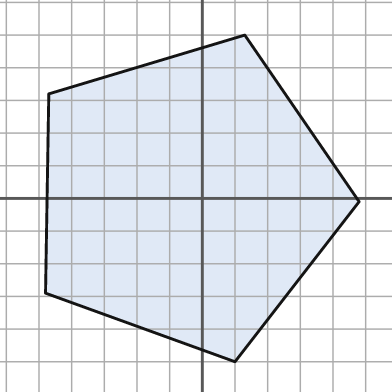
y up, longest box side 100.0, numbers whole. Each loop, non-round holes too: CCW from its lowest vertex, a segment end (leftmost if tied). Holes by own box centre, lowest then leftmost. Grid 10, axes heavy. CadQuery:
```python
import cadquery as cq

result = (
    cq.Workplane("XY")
    .moveTo(10.0, -50.0)
    .lineTo(48.0, -1.0)
    .lineTo(13.0, 50.0)
    .lineTo(-47.0, 32.0)
    .lineTo(-48.0, -29.0)
    .close()
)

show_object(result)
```